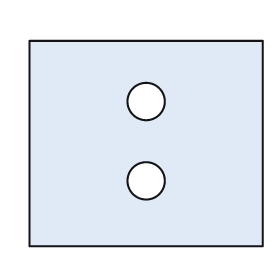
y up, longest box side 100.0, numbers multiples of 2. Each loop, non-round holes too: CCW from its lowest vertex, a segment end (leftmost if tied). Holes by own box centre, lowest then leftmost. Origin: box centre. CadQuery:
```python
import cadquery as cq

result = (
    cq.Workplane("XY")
    .moveTo(-50.0, -44.0)
    .lineTo(50.0, -44.0)
    .lineTo(50.0, 44.0)
    .lineTo(-50.0, 44.0)
    .close()
    .moveTo(0.0, -16.0)
    .circle(8.0)
    .moveTo(0.0, 18.0)
    .circle(8.0)
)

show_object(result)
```